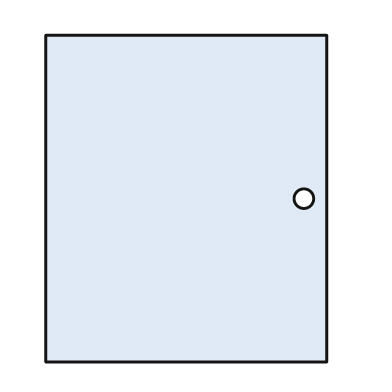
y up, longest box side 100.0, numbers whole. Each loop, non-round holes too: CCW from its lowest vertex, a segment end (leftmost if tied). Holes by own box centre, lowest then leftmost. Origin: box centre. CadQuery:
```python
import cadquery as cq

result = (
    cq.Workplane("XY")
    .moveTo(-43.0, -50.0)
    .lineTo(43.0, -50.0)
    .lineTo(43.0, 50.0)
    .lineTo(-43.0, 50.0)
    .close()
    .moveTo(36.0, 0.0)
    .circle(3.0)
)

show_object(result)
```